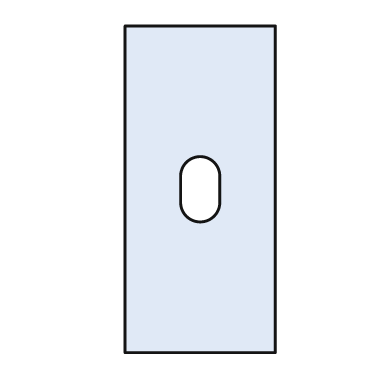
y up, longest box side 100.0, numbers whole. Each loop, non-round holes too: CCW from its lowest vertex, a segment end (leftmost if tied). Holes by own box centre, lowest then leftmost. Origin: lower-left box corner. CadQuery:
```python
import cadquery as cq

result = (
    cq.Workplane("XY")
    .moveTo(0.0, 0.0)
    .lineTo(46.0, 0.0)
    .lineTo(46.0, 100.0)
    .lineTo(0.0, 100.0)
    .close()
    .moveTo(17.0, 46.0)
    .threePointArc((23.0, 40.0), (29.0, 46.0))
    .lineTo(29.0, 54.0)
    .threePointArc((23.0, 60.0), (17.0, 54.0))
    .close()
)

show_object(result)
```